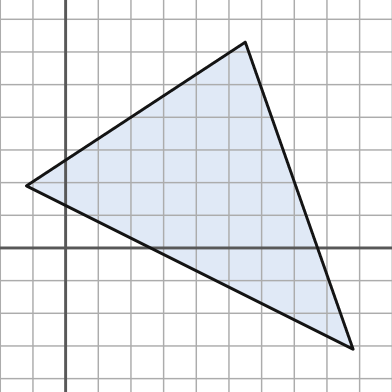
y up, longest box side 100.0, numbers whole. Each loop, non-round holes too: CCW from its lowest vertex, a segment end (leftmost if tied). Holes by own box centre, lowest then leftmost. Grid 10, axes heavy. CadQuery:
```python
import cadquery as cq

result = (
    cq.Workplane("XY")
    .moveTo(88.0, -31.0)
    .lineTo(55.0, 63.0)
    .lineTo(-12.0, 19.0)
    .close()
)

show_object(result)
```